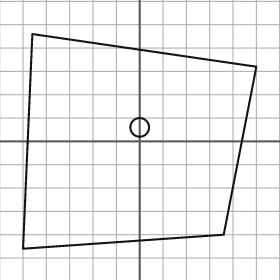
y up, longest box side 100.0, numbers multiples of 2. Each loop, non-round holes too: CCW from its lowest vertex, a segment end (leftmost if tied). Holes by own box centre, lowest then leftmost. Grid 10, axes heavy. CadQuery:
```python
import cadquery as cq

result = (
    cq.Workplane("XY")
    .moveTo(-50.0, -46.0)
    .lineTo(36.0, -40.0)
    .lineTo(50.0, 32.0)
    .lineTo(-46.0, 46.0)
    .close()
    .moveTo(0.0, 6.0)
    .circle(4.0)
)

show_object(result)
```